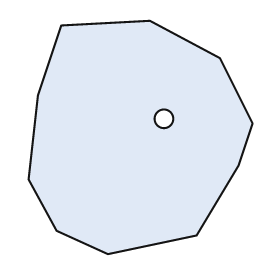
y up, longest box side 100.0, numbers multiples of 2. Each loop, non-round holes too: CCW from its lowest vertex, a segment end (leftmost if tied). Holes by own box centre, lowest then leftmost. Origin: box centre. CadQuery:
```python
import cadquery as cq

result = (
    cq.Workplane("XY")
    .moveTo(-14.0, -50.0)
    .lineTo(24.0, -42.0)
    .lineTo(42.0, -12.0)
    .lineTo(48.0, 6.0)
    .lineTo(34.0, 34.0)
    .lineTo(4.0, 50.0)
    .lineTo(-34.0, 48.0)
    .lineTo(-44.0, 18.0)
    .lineTo(-48.0, -18.0)
    .lineTo(-36.0, -40.0)
    .close()
    .moveTo(10.0, 8.0)
    .circle(4.0)
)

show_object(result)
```